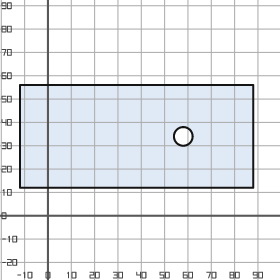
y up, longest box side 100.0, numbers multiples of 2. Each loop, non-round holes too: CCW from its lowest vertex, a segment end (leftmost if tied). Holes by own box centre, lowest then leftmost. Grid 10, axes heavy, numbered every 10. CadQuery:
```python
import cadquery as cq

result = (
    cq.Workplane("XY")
    .moveTo(-12.0, 12.0)
    .lineTo(88.0, 12.0)
    .lineTo(88.0, 56.0)
    .lineTo(-12.0, 56.0)
    .close()
    .moveTo(58.0, 34.0)
    .circle(4.0)
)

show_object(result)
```